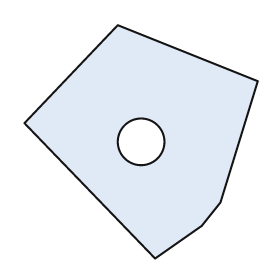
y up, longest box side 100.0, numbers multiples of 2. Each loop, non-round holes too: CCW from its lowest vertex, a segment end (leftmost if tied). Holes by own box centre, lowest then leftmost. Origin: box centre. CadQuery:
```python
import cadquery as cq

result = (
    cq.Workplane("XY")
    .moveTo(6.0, -50.0)
    .lineTo(26.0, -36.0)
    .lineTo(34.0, -26.0)
    .lineTo(50.0, 26.0)
    .lineTo(-10.0, 50.0)
    .lineTo(-50.0, 8.0)
    .close()
    .moveTo(0.0, 0.0)
    .circle(10.0)
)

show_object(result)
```